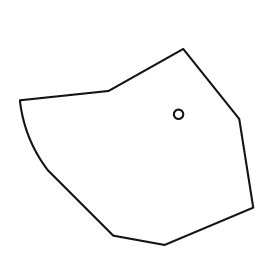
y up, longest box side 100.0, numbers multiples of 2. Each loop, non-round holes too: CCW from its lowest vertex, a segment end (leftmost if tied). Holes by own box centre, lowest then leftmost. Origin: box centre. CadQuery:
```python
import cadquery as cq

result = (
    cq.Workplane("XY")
    .moveTo(12.0, -42.0)
    .lineTo(50.0, -26.0)
    .lineTo(44.0, 12.0)
    .lineTo(20.0, 42.0)
    .lineTo(-12.0, 24.0)
    .lineTo(-50.0, 20.0)
    .threePointArc((-46.0, 4.0), (-38.0, -10.0))
    .lineTo(-10.0, -38.0)
    .close()
    .moveTo(18.0, 14.0)
    .circle(2.0)
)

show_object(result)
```